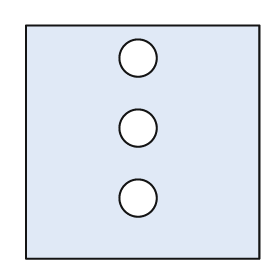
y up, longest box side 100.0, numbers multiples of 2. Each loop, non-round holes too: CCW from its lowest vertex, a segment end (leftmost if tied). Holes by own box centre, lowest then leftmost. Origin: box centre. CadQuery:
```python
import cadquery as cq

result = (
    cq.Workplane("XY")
    .moveTo(-50.0, -50.0)
    .lineTo(50.0, -50.0)
    .lineTo(50.0, 50.0)
    .lineTo(-50.0, 50.0)
    .close()
    .moveTo(-2.0, -24.0)
    .circle(8.0)
    .moveTo(-2.0, 6.0)
    .circle(8.0)
    .moveTo(-2.0, 36.0)
    .circle(8.0)
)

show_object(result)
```